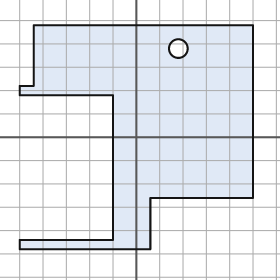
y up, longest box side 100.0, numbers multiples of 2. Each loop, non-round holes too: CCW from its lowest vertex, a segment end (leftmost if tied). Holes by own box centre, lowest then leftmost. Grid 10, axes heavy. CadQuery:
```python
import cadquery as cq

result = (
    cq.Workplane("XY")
    .moveTo(-50.0, -48.0)
    .lineTo(6.0, -48.0)
    .lineTo(6.0, -26.0)
    .lineTo(50.0, -26.0)
    .lineTo(50.0, 48.0)
    .lineTo(-44.0, 48.0)
    .lineTo(-44.0, 22.0)
    .lineTo(-50.0, 22.0)
    .lineTo(-50.0, 18.0)
    .lineTo(-10.0, 18.0)
    .lineTo(-10.0, -44.0)
    .lineTo(-50.0, -44.0)
    .close()
    .moveTo(18.0, 38.0)
    .circle(4.0)
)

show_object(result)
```